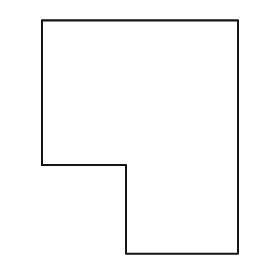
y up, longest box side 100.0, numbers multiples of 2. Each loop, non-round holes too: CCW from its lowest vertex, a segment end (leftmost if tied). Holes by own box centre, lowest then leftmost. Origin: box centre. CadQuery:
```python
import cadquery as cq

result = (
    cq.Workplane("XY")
    .moveTo(-6.0, -50.0)
    .lineTo(42.0, -50.0)
    .lineTo(42.0, 50.0)
    .lineTo(-42.0, 50.0)
    .lineTo(-42.0, -12.0)
    .lineTo(-6.0, -12.0)
    .close()
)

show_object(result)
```